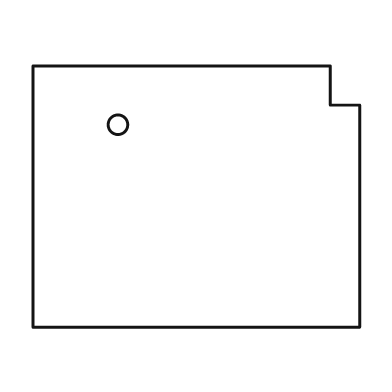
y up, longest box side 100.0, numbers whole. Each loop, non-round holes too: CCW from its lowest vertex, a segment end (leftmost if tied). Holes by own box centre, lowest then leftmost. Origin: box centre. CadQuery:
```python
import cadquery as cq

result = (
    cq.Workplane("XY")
    .moveTo(-50.0, -40.0)
    .lineTo(50.0, -40.0)
    .lineTo(50.0, 28.0)
    .lineTo(41.0, 28.0)
    .lineTo(41.0, 40.0)
    .lineTo(-50.0, 40.0)
    .close()
    .moveTo(-24.0, 22.0)
    .circle(3.0)
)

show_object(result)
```